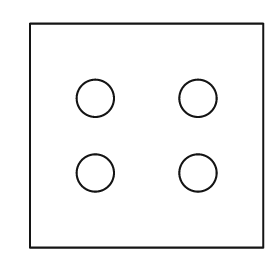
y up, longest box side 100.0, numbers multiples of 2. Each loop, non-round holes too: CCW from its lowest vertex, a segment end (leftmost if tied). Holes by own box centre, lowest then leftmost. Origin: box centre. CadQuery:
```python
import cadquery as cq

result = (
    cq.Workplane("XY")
    .moveTo(-50.0, -48.0)
    .lineTo(50.0, -48.0)
    .lineTo(50.0, 48.0)
    .lineTo(-50.0, 48.0)
    .close()
    .moveTo(-22.0, -16.0)
    .circle(8.0)
    .moveTo(22.0, -16.0)
    .circle(8.0)
    .moveTo(-22.0, 16.0)
    .circle(8.0)
    .moveTo(22.0, 16.0)
    .circle(8.0)
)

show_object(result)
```